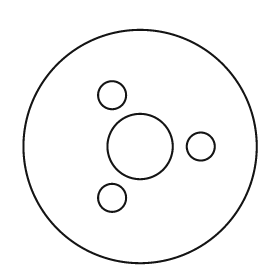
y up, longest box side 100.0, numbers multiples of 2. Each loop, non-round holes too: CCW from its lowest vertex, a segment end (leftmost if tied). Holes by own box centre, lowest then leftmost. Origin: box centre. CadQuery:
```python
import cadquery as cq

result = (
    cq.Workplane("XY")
    .moveTo(0.0, 0.0)
    .circle(50.0)
    .moveTo(-12.0, -22.0)
    .circle(6.0)
    .moveTo(0.0, 0.0)
    .circle(14.0)
    .moveTo(26.0, 0.0)
    .circle(6.0)
    .moveTo(-12.0, 22.0)
    .circle(6.0)
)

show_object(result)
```